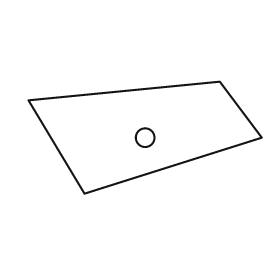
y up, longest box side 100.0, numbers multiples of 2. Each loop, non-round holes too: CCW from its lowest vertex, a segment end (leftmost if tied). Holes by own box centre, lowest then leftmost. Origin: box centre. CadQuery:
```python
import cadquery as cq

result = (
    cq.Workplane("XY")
    .moveTo(-26.0, -24.0)
    .lineTo(50.0, 0.0)
    .lineTo(32.0, 24.0)
    .lineTo(-50.0, 16.0)
    .close()
    .moveTo(0.0, 0.0)
    .circle(4.0)
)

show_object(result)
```